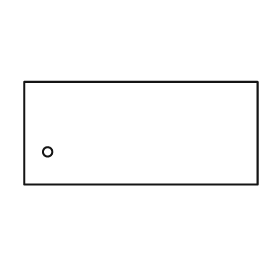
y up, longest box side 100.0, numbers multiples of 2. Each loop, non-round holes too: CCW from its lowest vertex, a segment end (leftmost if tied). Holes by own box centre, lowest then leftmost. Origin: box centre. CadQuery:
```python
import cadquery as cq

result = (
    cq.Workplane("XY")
    .moveTo(-50.0, -22.0)
    .lineTo(50.0, -22.0)
    .lineTo(50.0, 22.0)
    .lineTo(-50.0, 22.0)
    .close()
    .moveTo(-40.0, -8.0)
    .circle(2.0)
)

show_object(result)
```